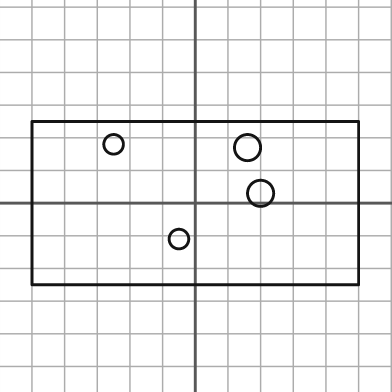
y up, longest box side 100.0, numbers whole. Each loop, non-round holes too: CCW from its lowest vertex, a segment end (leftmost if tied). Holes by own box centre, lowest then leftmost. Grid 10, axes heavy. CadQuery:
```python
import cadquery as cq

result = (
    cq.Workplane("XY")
    .moveTo(-50.0, -25.0)
    .lineTo(50.0, -25.0)
    .lineTo(50.0, 25.0)
    .lineTo(-50.0, 25.0)
    .close()
    .moveTo(-5.0, -11.0)
    .circle(3.0)
    .moveTo(20.0, 3.0)
    .circle(4.0)
    .moveTo(16.0, 17.0)
    .circle(4.0)
    .moveTo(-25.0, 18.0)
    .circle(3.0)
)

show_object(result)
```